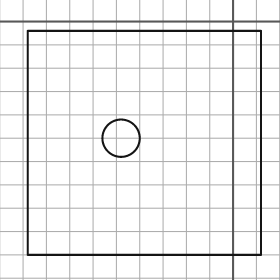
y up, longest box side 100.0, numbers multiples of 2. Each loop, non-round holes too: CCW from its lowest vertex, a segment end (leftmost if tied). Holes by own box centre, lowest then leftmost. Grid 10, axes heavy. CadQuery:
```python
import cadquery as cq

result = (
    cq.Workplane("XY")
    .moveTo(-88.0, -100.0)
    .lineTo(12.0, -100.0)
    .lineTo(12.0, -4.0)
    .lineTo(-88.0, -4.0)
    .close()
    .moveTo(-48.0, -50.0)
    .circle(8.0)
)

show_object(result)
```